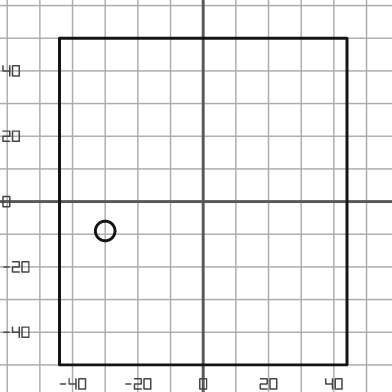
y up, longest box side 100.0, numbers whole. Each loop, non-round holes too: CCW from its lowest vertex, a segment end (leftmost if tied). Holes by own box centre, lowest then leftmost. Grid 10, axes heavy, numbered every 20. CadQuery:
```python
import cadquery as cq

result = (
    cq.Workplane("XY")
    .moveTo(-44.0, -50.0)
    .lineTo(44.0, -50.0)
    .lineTo(44.0, 50.0)
    .lineTo(-44.0, 50.0)
    .close()
    .moveTo(-30.0, -9.0)
    .circle(3.0)
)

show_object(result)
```